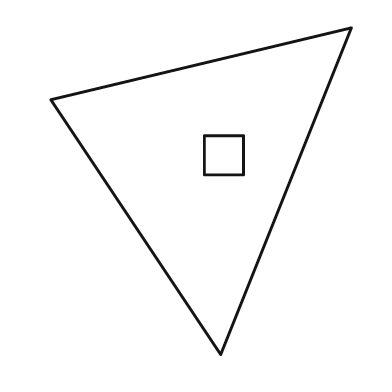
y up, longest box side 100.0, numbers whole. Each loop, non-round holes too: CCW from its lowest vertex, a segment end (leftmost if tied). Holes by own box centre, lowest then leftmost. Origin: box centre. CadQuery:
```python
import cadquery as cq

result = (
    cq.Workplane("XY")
    .moveTo(6.0, -50.0)
    .lineTo(46.0, 50.0)
    .lineTo(-46.0, 28.0)
    .close()
    .moveTo(1.0, 5.0)
    .lineTo(13.0, 5.0)
    .lineTo(13.0, 17.0)
    .lineTo(1.0, 17.0)
    .close()
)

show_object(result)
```